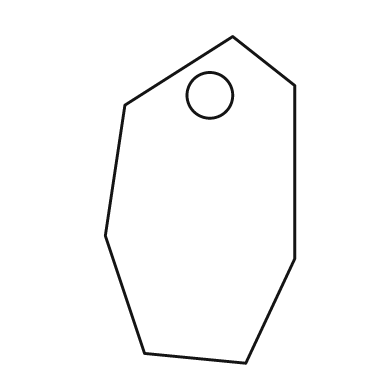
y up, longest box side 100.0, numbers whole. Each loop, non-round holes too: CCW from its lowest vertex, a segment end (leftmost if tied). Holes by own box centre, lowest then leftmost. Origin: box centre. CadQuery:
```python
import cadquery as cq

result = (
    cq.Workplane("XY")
    .moveTo(14.0, -50.0)
    .lineTo(29.0, -18.0)
    .lineTo(29.0, 35.0)
    .lineTo(10.0, 50.0)
    .lineTo(-23.0, 29.0)
    .lineTo(-29.0, -11.0)
    .lineTo(-17.0, -47.0)
    .close()
    .moveTo(3.0, 32.0)
    .circle(7.0)
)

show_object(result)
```